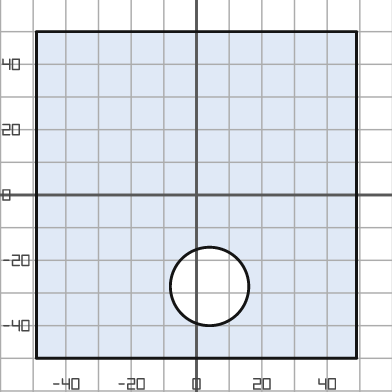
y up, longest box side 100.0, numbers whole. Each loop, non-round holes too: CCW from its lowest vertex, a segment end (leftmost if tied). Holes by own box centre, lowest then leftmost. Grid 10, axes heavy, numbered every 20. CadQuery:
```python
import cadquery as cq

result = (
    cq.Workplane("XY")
    .moveTo(-49.0, -50.0)
    .lineTo(49.0, -50.0)
    .lineTo(49.0, 50.0)
    .lineTo(-49.0, 50.0)
    .close()
    .moveTo(4.0, -28.0)
    .circle(12.0)
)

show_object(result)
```